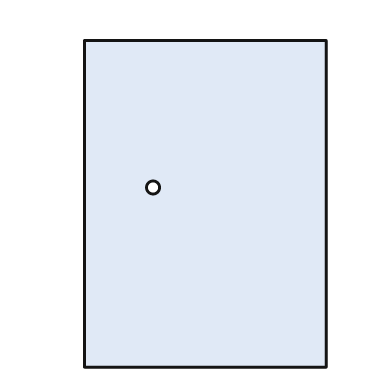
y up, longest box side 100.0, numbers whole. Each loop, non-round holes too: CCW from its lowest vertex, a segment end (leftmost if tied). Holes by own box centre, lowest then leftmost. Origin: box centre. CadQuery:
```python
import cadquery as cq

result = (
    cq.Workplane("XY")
    .moveTo(-37.0, -50.0)
    .lineTo(37.0, -50.0)
    .lineTo(37.0, 50.0)
    .lineTo(-37.0, 50.0)
    .close()
    .moveTo(-16.0, 5.0)
    .circle(2.0)
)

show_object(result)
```